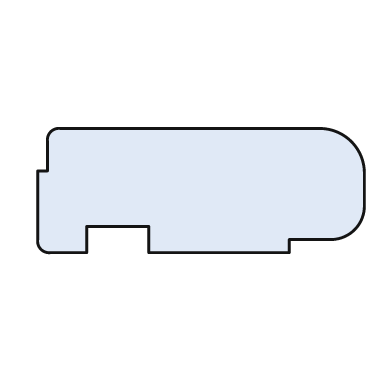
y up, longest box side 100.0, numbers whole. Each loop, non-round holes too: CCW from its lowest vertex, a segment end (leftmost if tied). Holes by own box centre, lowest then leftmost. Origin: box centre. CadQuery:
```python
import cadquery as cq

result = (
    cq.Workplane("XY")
    .moveTo(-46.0, -19.0)
    .lineTo(-35.0, -19.0)
    .lineTo(-35.0, -11.0)
    .lineTo(-16.0, -11.0)
    .lineTo(-16.0, -19.0)
    .lineTo(27.0, -19.0)
    .lineTo(27.0, -15.0)
    .lineTo(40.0, -15.0)
    .threePointArc((47.0, -12.0), (50.0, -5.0))
    .lineTo(50.0, 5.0)
    .threePointArc((46.0, 15.0), (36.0, 19.0))
    .lineTo(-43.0, 19.0)
    .threePointArc((-46.0, 18.0), (-47.0, 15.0))
    .lineTo(-47.0, 6.0)
    .lineTo(-50.0, 6.0)
    .lineTo(-50.0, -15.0)
    .threePointArc((-49.0, -18.0), (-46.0, -19.0))
    .close()
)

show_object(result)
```